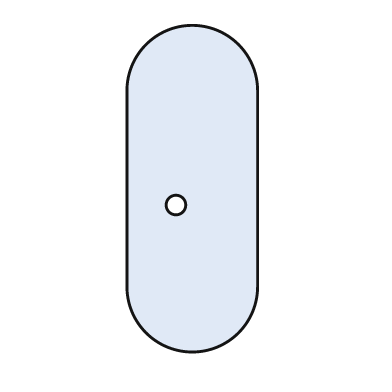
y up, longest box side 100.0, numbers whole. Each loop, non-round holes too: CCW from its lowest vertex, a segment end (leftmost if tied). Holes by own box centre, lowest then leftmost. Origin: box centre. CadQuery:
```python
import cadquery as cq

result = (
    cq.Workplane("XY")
    .moveTo(-20.0, -30.0)
    .threePointArc((0.0, -50.0), (20.0, -30.0))
    .lineTo(20.0, 30.0)
    .threePointArc((0.0, 50.0), (-20.0, 30.0))
    .close()
    .moveTo(-5.0, -5.0)
    .circle(3.0)
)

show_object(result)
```